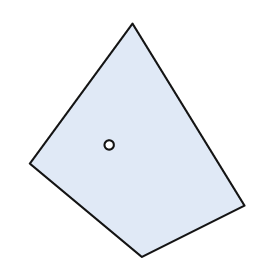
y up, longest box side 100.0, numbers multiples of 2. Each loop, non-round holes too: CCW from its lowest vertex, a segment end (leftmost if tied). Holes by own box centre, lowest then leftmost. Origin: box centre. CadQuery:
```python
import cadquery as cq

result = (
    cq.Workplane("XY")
    .moveTo(2.0, -50.0)
    .lineTo(46.0, -28.0)
    .lineTo(-2.0, 50.0)
    .lineTo(-46.0, -10.0)
    .close()
    .moveTo(-12.0, -2.0)
    .circle(2.0)
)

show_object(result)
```